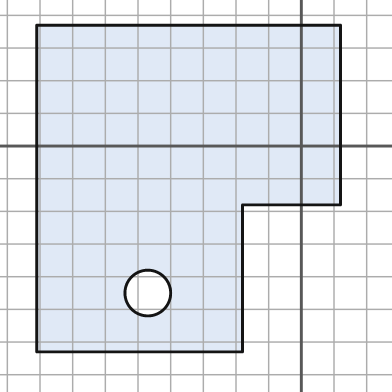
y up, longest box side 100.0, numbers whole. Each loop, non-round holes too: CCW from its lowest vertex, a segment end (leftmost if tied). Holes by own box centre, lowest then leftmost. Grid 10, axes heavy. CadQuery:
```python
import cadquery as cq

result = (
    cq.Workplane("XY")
    .moveTo(-81.0, -63.0)
    .lineTo(-18.0, -63.0)
    .lineTo(-18.0, -18.0)
    .lineTo(12.0, -18.0)
    .lineTo(12.0, 37.0)
    .lineTo(-81.0, 37.0)
    .close()
    .moveTo(-47.0, -45.0)
    .circle(7.0)
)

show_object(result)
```